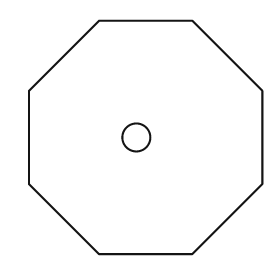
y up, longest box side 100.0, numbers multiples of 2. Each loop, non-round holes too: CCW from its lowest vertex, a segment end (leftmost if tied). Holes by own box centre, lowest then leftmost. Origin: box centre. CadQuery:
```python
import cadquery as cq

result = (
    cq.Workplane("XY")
    .moveTo(-20.0, -50.0)
    .lineTo(20.0, -50.0)
    .lineTo(50.0, -20.0)
    .lineTo(50.0, 20.0)
    .lineTo(20.0, 50.0)
    .lineTo(-20.0, 50.0)
    .lineTo(-50.0, 20.0)
    .lineTo(-50.0, -20.0)
    .close()
    .moveTo(-4.0, 0.0)
    .circle(6.0)
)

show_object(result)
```